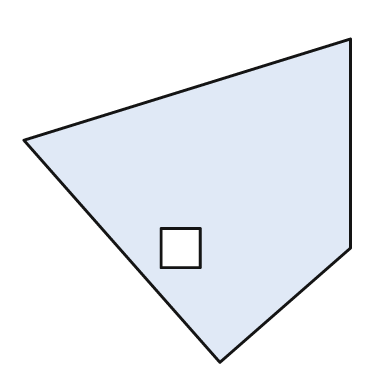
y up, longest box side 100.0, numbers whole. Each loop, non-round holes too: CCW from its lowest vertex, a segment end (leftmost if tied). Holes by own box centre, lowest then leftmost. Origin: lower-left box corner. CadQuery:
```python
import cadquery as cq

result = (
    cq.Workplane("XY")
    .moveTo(60.0, 0.0)
    .lineTo(100.0, 35.0)
    .lineTo(100.0, 99.0)
    .lineTo(0.0, 68.0)
    .close()
    .moveTo(42.0, 29.0)
    .lineTo(54.0, 29.0)
    .lineTo(54.0, 41.0)
    .lineTo(42.0, 41.0)
    .close()
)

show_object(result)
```